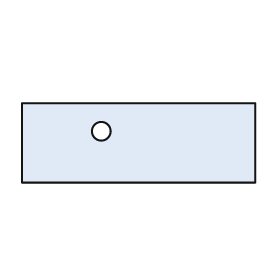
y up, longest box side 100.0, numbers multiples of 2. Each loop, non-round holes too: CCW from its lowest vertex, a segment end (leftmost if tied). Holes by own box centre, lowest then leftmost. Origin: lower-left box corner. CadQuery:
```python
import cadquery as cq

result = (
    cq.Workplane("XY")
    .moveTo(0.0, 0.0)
    .lineTo(100.0, 0.0)
    .lineTo(100.0, 34.0)
    .lineTo(0.0, 34.0)
    .close()
    .moveTo(34.0, 22.0)
    .circle(4.0)
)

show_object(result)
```